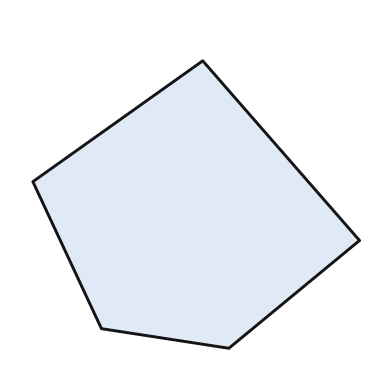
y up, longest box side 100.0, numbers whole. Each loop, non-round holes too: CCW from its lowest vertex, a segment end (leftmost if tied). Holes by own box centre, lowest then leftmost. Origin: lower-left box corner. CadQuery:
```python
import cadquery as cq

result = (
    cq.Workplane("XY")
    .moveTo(60.0, 0.0)
    .lineTo(100.0, 33.0)
    .lineTo(52.0, 88.0)
    .lineTo(0.0, 51.0)
    .lineTo(21.0, 6.0)
    .close()
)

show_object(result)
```